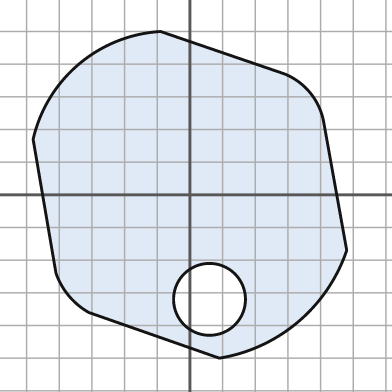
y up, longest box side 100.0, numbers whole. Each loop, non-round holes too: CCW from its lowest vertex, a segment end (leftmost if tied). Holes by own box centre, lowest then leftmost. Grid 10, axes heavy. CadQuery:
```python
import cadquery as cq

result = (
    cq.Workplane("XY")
    .moveTo(9.0, -50.0)
    .threePointArc((33.0, -39.0), (48.0, -17.0))
    .lineTo(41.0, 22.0)
    .threePointArc((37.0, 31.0), (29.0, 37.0))
    .lineTo(-9.0, 50.0)
    .threePointArc((-34.0, 40.0), (-48.0, 17.0))
    .lineTo(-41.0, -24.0)
    .threePointArc((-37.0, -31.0), (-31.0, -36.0))
    .close()
    .moveTo(6.0, -32.0)
    .circle(11.0)
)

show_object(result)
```